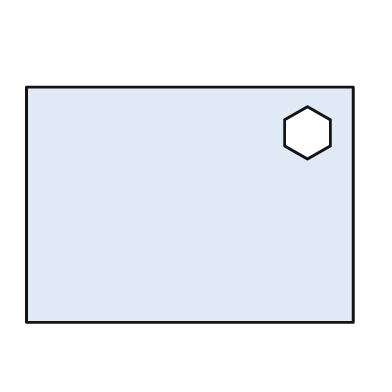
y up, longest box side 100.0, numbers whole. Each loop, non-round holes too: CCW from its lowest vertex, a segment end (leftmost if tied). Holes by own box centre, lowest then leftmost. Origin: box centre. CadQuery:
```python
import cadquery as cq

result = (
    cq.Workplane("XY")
    .moveTo(-50.0, -36.0)
    .lineTo(50.0, -36.0)
    .lineTo(50.0, 36.0)
    .lineTo(-50.0, 36.0)
    .close()
    .moveTo(36.0, 14.0)
    .lineTo(43.0, 18.0)
    .lineTo(43.0, 26.0)
    .lineTo(36.0, 30.0)
    .lineTo(29.0, 26.0)
    .lineTo(29.0, 18.0)
    .close()
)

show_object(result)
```